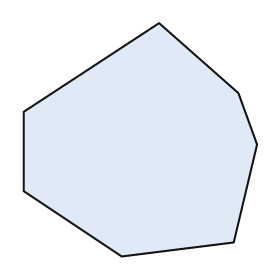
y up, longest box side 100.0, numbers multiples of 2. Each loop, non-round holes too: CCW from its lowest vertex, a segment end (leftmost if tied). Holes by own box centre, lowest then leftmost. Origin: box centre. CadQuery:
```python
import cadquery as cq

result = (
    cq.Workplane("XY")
    .moveTo(-8.0, -50.0)
    .lineTo(40.0, -44.0)
    .lineTo(50.0, -2.0)
    .lineTo(42.0, 20.0)
    .lineTo(8.0, 50.0)
    .lineTo(-50.0, 12.0)
    .lineTo(-50.0, -22.0)
    .close()
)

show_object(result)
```